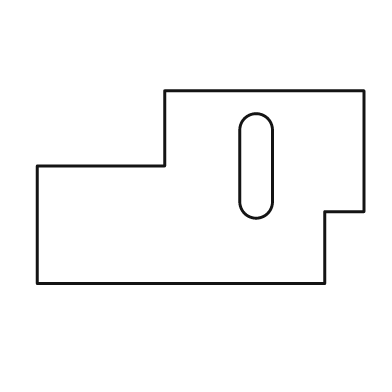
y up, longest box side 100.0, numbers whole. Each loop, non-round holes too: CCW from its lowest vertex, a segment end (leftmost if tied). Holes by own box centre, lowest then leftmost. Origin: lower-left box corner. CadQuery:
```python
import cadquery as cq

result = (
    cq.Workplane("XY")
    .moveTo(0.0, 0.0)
    .lineTo(88.0, 0.0)
    .lineTo(88.0, 22.0)
    .lineTo(100.0, 22.0)
    .lineTo(100.0, 59.0)
    .lineTo(39.0, 59.0)
    .lineTo(39.0, 36.0)
    .lineTo(0.0, 36.0)
    .close()
    .moveTo(62.0, 25.0)
    .threePointArc((67.0, 20.0), (72.0, 25.0))
    .lineTo(72.0, 47.0)
    .threePointArc((67.0, 52.0), (62.0, 47.0))
    .close()
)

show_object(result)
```